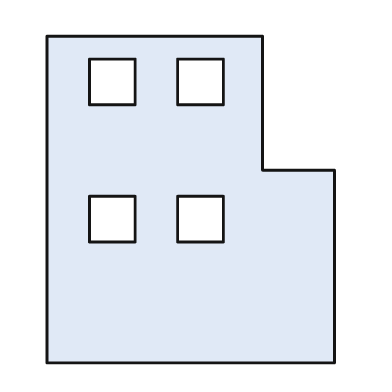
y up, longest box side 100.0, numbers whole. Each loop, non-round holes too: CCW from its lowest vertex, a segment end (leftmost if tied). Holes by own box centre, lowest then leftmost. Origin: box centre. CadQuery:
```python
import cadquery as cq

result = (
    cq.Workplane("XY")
    .moveTo(-44.0, -50.0)
    .lineTo(44.0, -50.0)
    .lineTo(44.0, 9.0)
    .lineTo(22.0, 9.0)
    .lineTo(22.0, 50.0)
    .lineTo(-44.0, 50.0)
    .close()
    .moveTo(-31.0, -13.0)
    .lineTo(-17.0, -13.0)
    .lineTo(-17.0, 1.0)
    .lineTo(-31.0, 1.0)
    .close()
    .moveTo(-4.0, -13.0)
    .lineTo(10.0, -13.0)
    .lineTo(10.0, 1.0)
    .lineTo(-4.0, 1.0)
    .close()
    .moveTo(-31.0, 29.0)
    .lineTo(-17.0, 29.0)
    .lineTo(-17.0, 43.0)
    .lineTo(-31.0, 43.0)
    .close()
    .moveTo(-4.0, 29.0)
    .lineTo(10.0, 29.0)
    .lineTo(10.0, 43.0)
    .lineTo(-4.0, 43.0)
    .close()
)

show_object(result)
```